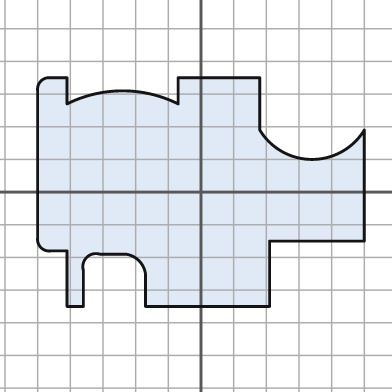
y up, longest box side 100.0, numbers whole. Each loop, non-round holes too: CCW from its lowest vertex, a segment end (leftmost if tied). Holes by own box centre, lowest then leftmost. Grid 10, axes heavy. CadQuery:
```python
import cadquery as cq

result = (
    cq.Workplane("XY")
    .moveTo(-41.0, -35.0)
    .lineTo(-36.0, -35.0)
    .lineTo(-36.0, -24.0)
    .threePointArc((-35.0, -20.0), (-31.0, -19.0))
    .lineTo(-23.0, -19.0)
    .threePointArc((-19.0, -21.0), (-17.0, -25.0))
    .lineTo(-17.0, -35.0)
    .lineTo(21.0, -35.0)
    .lineTo(21.0, -15.0)
    .lineTo(50.0, -15.0)
    .lineTo(50.0, 19.0)
    .threePointArc((34.0, 10.0), (18.0, 19.0))
    .lineTo(18.0, 35.0)
    .lineTo(-7.0, 35.0)
    .lineTo(-7.0, 27.0)
    .threePointArc((-24.0, 31.0), (-41.0, 27.0))
    .lineTo(-41.0, 35.0)
    .lineTo(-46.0, 35.0)
    .threePointArc((-49.0, 34.0), (-50.0, 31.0))
    .lineTo(-50.0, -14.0)
    .threePointArc((-49.0, -17.0), (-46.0, -18.0))
    .lineTo(-41.0, -18.0)
    .close()
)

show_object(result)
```